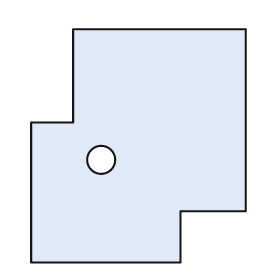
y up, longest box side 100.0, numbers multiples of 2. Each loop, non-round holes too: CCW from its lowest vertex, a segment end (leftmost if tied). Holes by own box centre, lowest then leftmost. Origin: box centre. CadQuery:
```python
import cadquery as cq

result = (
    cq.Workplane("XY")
    .moveTo(-46.0, -50.0)
    .lineTo(18.0, -50.0)
    .lineTo(18.0, -28.0)
    .lineTo(46.0, -28.0)
    .lineTo(46.0, 50.0)
    .lineTo(-28.0, 50.0)
    .lineTo(-28.0, 10.0)
    .lineTo(-46.0, 10.0)
    .close()
    .moveTo(-16.0, -6.0)
    .circle(6.0)
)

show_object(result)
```